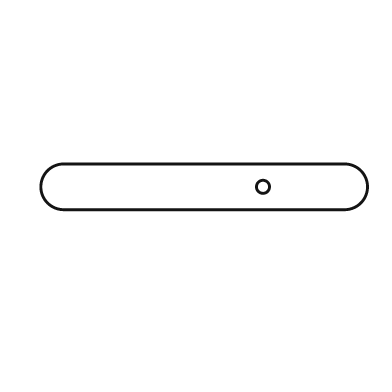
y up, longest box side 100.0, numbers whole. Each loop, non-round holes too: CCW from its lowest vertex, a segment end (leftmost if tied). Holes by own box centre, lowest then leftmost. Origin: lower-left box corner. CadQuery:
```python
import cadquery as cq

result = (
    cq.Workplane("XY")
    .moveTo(7.0, 0.0)
    .lineTo(93.0, 0.0)
    .threePointArc((100.0, 7.0), (93.0, 14.0))
    .lineTo(7.0, 14.0)
    .threePointArc((0.0, 7.0), (7.0, 0.0))
    .close()
    .moveTo(68.0, 7.0)
    .circle(2.0)
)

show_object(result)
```